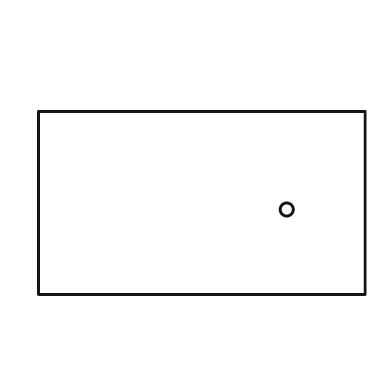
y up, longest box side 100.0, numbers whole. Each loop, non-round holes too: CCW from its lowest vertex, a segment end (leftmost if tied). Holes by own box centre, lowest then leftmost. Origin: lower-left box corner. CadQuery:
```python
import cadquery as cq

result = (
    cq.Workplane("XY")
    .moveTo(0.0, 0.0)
    .lineTo(100.0, 0.0)
    .lineTo(100.0, 56.0)
    .lineTo(0.0, 56.0)
    .close()
    .moveTo(76.0, 26.0)
    .circle(2.0)
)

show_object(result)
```